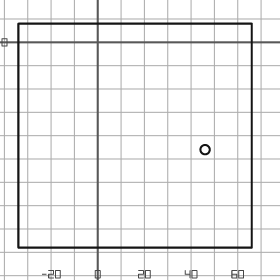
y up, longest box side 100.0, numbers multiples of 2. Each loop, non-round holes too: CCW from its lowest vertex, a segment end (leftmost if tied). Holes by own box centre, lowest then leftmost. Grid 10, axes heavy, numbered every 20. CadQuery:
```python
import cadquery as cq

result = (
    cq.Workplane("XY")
    .moveTo(-34.0, -88.0)
    .lineTo(66.0, -88.0)
    .lineTo(66.0, 8.0)
    .lineTo(-34.0, 8.0)
    .close()
    .moveTo(46.0, -46.0)
    .circle(2.0)
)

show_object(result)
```